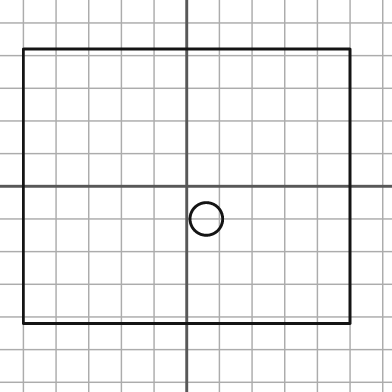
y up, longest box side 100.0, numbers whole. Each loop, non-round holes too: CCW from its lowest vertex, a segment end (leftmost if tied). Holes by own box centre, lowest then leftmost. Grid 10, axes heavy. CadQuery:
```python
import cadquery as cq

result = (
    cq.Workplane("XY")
    .moveTo(-50.0, -42.0)
    .lineTo(50.0, -42.0)
    .lineTo(50.0, 42.0)
    .lineTo(-50.0, 42.0)
    .close()
    .moveTo(6.0, -10.0)
    .circle(5.0)
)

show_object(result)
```